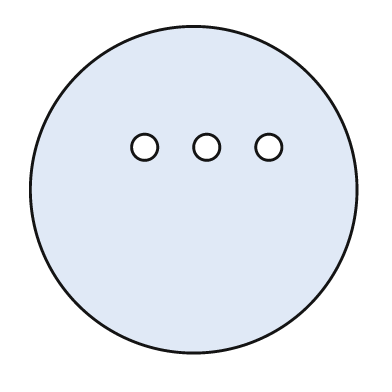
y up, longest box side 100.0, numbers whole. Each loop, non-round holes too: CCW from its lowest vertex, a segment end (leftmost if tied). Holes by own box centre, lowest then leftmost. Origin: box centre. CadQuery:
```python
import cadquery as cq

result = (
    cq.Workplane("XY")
    .moveTo(0.0, 0.0)
    .circle(50.0)
    .moveTo(-15.0, 13.0)
    .circle(4.0)
    .moveTo(4.0, 13.0)
    .circle(4.0)
    .moveTo(23.0, 13.0)
    .circle(4.0)
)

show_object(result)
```